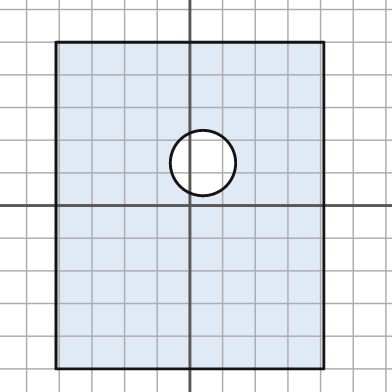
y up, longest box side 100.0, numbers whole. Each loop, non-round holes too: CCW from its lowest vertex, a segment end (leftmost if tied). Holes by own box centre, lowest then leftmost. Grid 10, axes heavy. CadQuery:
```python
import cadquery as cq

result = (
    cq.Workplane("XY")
    .moveTo(-41.0, -50.0)
    .lineTo(41.0, -50.0)
    .lineTo(41.0, 50.0)
    .lineTo(-41.0, 50.0)
    .close()
    .moveTo(4.0, 13.0)
    .circle(10.0)
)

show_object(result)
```